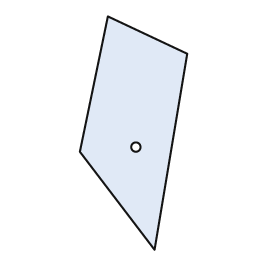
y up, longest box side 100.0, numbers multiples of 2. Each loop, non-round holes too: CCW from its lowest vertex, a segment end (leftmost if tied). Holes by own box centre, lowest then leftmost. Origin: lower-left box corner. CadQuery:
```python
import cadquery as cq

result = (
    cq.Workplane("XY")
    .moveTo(32.0, 0.0)
    .lineTo(46.0, 84.0)
    .lineTo(12.0, 100.0)
    .lineTo(0.0, 42.0)
    .close()
    .moveTo(24.0, 44.0)
    .circle(2.0)
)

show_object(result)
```